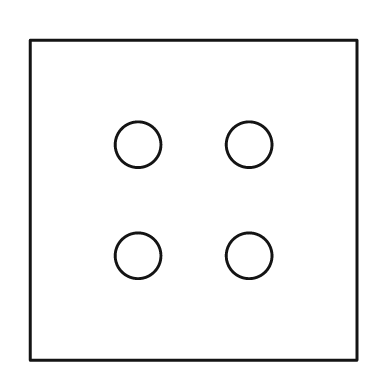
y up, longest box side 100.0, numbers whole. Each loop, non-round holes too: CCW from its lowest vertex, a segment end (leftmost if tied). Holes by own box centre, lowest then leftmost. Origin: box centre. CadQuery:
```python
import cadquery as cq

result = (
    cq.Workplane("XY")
    .moveTo(-50.0, -49.0)
    .lineTo(50.0, -49.0)
    .lineTo(50.0, 49.0)
    .lineTo(-50.0, 49.0)
    .close()
    .moveTo(-17.0, -17.0)
    .circle(7.0)
    .moveTo(17.0, -17.0)
    .circle(7.0)
    .moveTo(-17.0, 17.0)
    .circle(7.0)
    .moveTo(17.0, 17.0)
    .circle(7.0)
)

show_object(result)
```